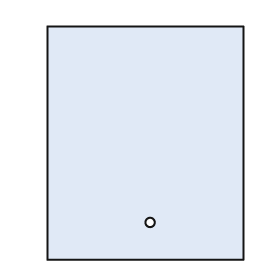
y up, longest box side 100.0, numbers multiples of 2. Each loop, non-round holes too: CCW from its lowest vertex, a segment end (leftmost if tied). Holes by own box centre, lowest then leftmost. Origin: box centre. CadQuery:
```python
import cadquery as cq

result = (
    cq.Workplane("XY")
    .moveTo(-42.0, -50.0)
    .lineTo(42.0, -50.0)
    .lineTo(42.0, 50.0)
    .lineTo(-42.0, 50.0)
    .close()
    .moveTo(2.0, -34.0)
    .circle(2.0)
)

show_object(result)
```